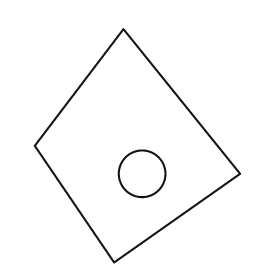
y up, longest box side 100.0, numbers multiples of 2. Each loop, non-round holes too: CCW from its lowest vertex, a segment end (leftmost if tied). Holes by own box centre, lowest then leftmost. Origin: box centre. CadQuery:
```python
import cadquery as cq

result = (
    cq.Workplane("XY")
    .moveTo(-10.0, -50.0)
    .lineTo(44.0, -12.0)
    .lineTo(-6.0, 50.0)
    .lineTo(-44.0, 0.0)
    .close()
    .moveTo(2.0, -12.0)
    .circle(10.0)
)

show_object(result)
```